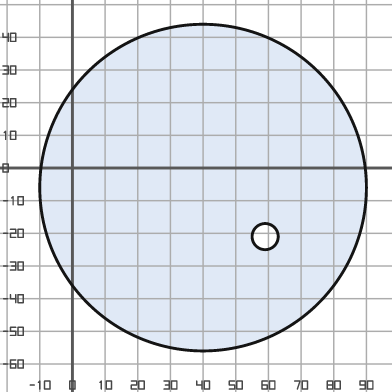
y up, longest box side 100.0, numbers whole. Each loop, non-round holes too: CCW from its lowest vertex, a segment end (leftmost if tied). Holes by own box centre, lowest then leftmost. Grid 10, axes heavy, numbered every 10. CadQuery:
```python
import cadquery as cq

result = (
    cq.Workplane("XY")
    .moveTo(40.0, -6.0)
    .circle(50.0)
    .moveTo(59.0, -21.0)
    .circle(4.0)
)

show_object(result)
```